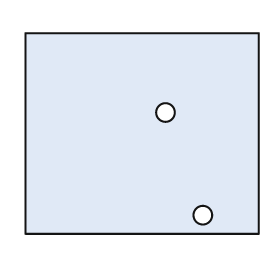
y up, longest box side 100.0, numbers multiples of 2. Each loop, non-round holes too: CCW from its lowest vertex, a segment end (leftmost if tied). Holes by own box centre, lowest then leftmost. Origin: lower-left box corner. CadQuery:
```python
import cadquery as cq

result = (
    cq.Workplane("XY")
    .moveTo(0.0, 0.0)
    .lineTo(100.0, 0.0)
    .lineTo(100.0, 86.0)
    .lineTo(0.0, 86.0)
    .close()
    .moveTo(76.0, 8.0)
    .circle(4.0)
    .moveTo(60.0, 52.0)
    .circle(4.0)
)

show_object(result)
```